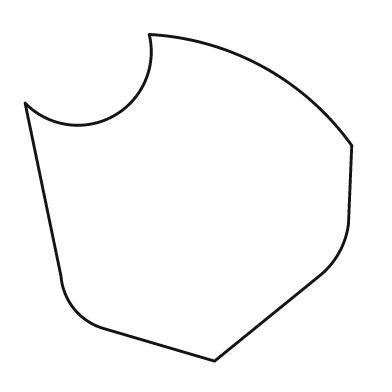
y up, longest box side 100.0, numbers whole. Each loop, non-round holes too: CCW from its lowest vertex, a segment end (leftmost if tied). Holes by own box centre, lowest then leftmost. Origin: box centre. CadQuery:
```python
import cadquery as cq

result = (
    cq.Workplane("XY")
    .moveTo(8.0, -50.0)
    .lineTo(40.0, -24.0)
    .threePointArc((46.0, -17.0), (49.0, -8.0))
    .lineTo(50.0, 16.0)
    .threePointArc((23.0, 40.0), (-12.0, 50.0))
    .threePointArc((-23.0, 25.0), (-50.0, 29.0))
    .lineTo(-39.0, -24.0)
    .threePointArc((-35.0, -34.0), (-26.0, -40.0))
    .close()
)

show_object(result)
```